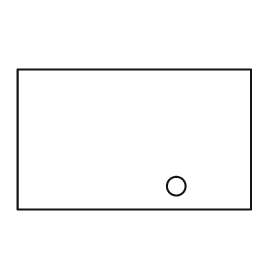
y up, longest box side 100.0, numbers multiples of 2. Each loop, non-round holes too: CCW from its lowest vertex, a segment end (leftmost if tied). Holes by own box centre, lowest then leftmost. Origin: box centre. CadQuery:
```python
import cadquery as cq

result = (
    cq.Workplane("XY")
    .moveTo(-50.0, -30.0)
    .lineTo(50.0, -30.0)
    .lineTo(50.0, 30.0)
    .lineTo(-50.0, 30.0)
    .close()
    .moveTo(18.0, -20.0)
    .circle(4.0)
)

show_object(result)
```